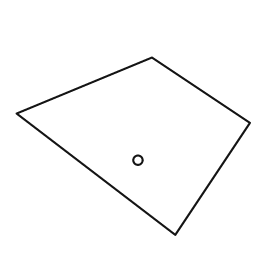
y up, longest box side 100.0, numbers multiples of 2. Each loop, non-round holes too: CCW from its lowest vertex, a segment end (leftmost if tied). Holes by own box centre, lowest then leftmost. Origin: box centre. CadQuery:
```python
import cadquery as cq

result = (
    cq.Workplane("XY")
    .moveTo(18.0, -38.0)
    .lineTo(50.0, 10.0)
    .lineTo(8.0, 38.0)
    .lineTo(-50.0, 14.0)
    .close()
    .moveTo(2.0, -6.0)
    .circle(2.0)
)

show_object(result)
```